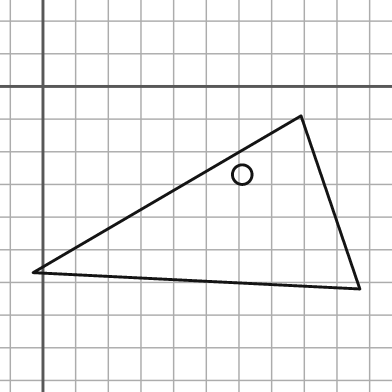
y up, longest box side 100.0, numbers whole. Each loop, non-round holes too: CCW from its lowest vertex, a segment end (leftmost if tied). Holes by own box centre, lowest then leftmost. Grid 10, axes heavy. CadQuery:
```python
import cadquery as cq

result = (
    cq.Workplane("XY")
    .moveTo(97.0, -62.0)
    .lineTo(79.0, -9.0)
    .lineTo(-3.0, -57.0)
    .close()
    .moveTo(61.0, -27.0)
    .circle(3.0)
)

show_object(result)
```